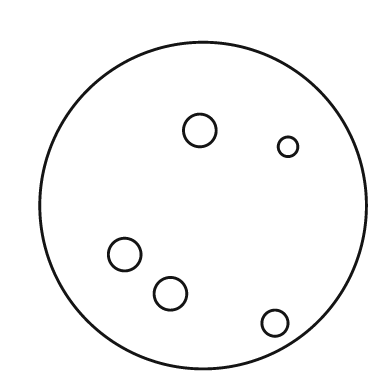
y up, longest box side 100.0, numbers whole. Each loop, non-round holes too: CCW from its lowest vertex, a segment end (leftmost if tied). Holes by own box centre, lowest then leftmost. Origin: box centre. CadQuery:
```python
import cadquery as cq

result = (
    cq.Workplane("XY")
    .moveTo(0.0, 0.0)
    .circle(50.0)
    .moveTo(22.0, -36.0)
    .circle(4.0)
    .moveTo(-10.0, -27.0)
    .circle(5.0)
    .moveTo(-24.0, -15.0)
    .circle(5.0)
    .moveTo(26.0, 18.0)
    .circle(3.0)
    .moveTo(-1.0, 23.0)
    .circle(5.0)
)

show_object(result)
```